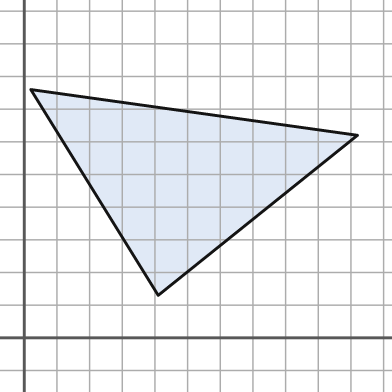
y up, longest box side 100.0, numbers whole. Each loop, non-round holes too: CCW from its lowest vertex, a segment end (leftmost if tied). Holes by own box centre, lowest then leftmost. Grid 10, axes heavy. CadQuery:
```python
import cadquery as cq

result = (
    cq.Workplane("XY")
    .moveTo(41.0, 13.0)
    .lineTo(102.0, 62.0)
    .lineTo(2.0, 76.0)
    .close()
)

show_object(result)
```